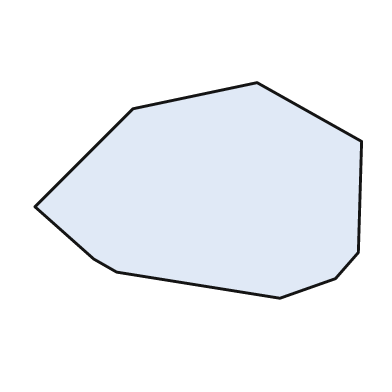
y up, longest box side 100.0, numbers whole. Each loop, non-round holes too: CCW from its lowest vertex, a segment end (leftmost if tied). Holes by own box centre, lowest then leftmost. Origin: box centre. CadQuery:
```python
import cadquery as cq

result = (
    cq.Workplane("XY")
    .moveTo(25.0, -33.0)
    .lineTo(42.0, -27.0)
    .lineTo(49.0, -19.0)
    .lineTo(50.0, 15.0)
    .lineTo(18.0, 33.0)
    .lineTo(-20.0, 25.0)
    .lineTo(-50.0, -5.0)
    .lineTo(-32.0, -21.0)
    .lineTo(-25.0, -25.0)
    .close()
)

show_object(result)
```